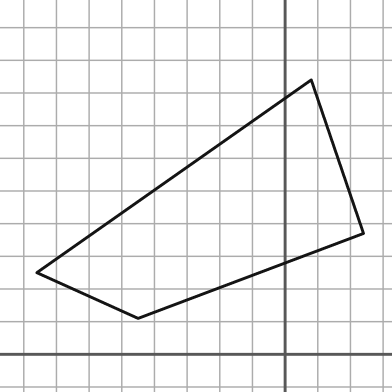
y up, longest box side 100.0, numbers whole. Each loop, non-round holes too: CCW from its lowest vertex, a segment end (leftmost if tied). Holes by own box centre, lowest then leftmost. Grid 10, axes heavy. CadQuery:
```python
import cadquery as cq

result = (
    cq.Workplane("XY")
    .moveTo(-45.0, 11.0)
    .lineTo(24.0, 37.0)
    .lineTo(8.0, 84.0)
    .lineTo(-76.0, 25.0)
    .close()
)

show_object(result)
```